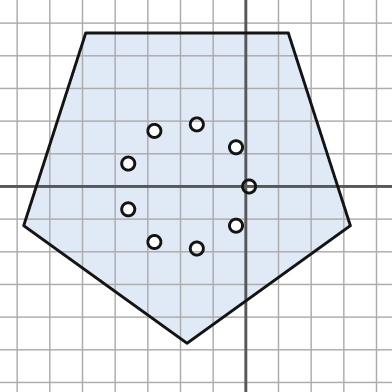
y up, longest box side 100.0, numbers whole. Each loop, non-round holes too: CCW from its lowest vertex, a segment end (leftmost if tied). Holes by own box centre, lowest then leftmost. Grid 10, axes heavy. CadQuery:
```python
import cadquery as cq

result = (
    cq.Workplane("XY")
    .moveTo(-18.0, -48.0)
    .lineTo(32.0, -12.0)
    .lineTo(13.0, 47.0)
    .lineTo(-49.0, 47.0)
    .lineTo(-68.0, -12.0)
    .close()
    .moveTo(-15.0, -19.0)
    .circle(2.0)
    .moveTo(-28.0, -17.0)
    .circle(2.0)
    .moveTo(-3.0, -12.0)
    .circle(2.0)
    .moveTo(-36.0, -7.0)
    .circle(2.0)
    .moveTo(1.0, 0.0)
    .circle(2.0)
    .moveTo(-36.0, 7.0)
    .circle(2.0)
    .moveTo(-3.0, 12.0)
    .circle(2.0)
    .moveTo(-28.0, 17.0)
    .circle(2.0)
    .moveTo(-15.0, 19.0)
    .circle(2.0)
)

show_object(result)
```